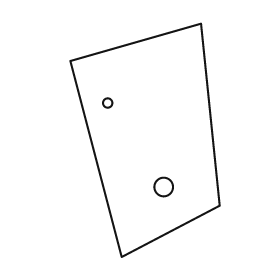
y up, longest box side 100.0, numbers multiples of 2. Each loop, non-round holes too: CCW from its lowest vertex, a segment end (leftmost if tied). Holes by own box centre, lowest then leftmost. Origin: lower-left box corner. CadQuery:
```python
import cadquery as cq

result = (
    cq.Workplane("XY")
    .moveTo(22.0, 0.0)
    .lineTo(64.0, 22.0)
    .lineTo(56.0, 100.0)
    .lineTo(0.0, 84.0)
    .close()
    .moveTo(40.0, 30.0)
    .circle(4.0)
    .moveTo(16.0, 66.0)
    .circle(2.0)
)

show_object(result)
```